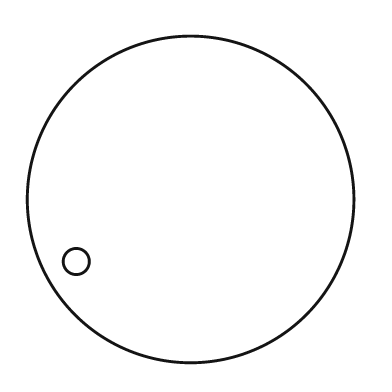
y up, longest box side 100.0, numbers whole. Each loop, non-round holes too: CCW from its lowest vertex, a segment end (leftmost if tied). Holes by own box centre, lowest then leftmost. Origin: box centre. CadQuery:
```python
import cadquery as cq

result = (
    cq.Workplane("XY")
    .moveTo(0.0, 0.0)
    .circle(50.0)
    .moveTo(-35.0, -19.0)
    .circle(4.0)
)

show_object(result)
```